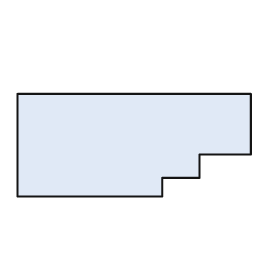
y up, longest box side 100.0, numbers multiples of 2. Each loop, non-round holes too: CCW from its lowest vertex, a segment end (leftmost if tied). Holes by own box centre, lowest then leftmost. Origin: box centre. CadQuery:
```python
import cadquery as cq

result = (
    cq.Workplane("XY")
    .moveTo(-50.0, -22.0)
    .lineTo(12.0, -22.0)
    .lineTo(12.0, -14.0)
    .lineTo(28.0, -14.0)
    .lineTo(28.0, -4.0)
    .lineTo(50.0, -4.0)
    .lineTo(50.0, 22.0)
    .lineTo(-50.0, 22.0)
    .close()
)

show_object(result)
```